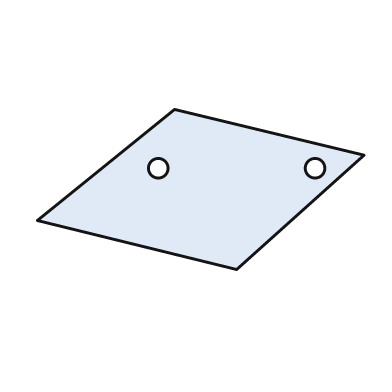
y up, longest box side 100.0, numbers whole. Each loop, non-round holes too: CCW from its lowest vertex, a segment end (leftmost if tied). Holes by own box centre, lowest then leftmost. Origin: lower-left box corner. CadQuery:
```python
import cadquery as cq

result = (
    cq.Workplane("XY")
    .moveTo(61.0, 0.0)
    .lineTo(100.0, 35.0)
    .lineTo(42.0, 49.0)
    .lineTo(0.0, 15.0)
    .close()
    .moveTo(37.0, 31.0)
    .circle(3.0)
    .moveTo(85.0, 31.0)
    .circle(3.0)
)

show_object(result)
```